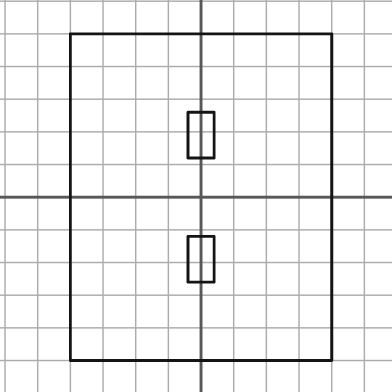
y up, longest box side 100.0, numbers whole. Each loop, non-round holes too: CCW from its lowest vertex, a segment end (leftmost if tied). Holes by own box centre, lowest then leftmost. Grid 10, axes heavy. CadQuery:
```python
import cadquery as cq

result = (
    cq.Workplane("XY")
    .moveTo(-40.0, -50.0)
    .lineTo(40.0, -50.0)
    .lineTo(40.0, 50.0)
    .lineTo(-40.0, 50.0)
    .close()
    .moveTo(-4.0, -26.0)
    .lineTo(4.0, -26.0)
    .lineTo(4.0, -12.0)
    .lineTo(-4.0, -12.0)
    .close()
    .moveTo(-4.0, 12.0)
    .lineTo(4.0, 12.0)
    .lineTo(4.0, 26.0)
    .lineTo(-4.0, 26.0)
    .close()
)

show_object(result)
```